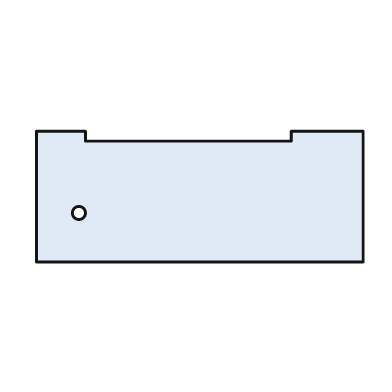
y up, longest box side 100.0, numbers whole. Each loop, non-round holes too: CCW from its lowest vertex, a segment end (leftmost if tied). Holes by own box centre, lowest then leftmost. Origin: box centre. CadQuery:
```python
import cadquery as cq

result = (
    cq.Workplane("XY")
    .moveTo(-50.0, -20.0)
    .lineTo(50.0, -20.0)
    .lineTo(50.0, 20.0)
    .lineTo(28.0, 20.0)
    .lineTo(28.0, 17.0)
    .lineTo(-35.0, 17.0)
    .lineTo(-35.0, 20.0)
    .lineTo(-50.0, 20.0)
    .close()
    .moveTo(-37.0, -5.0)
    .circle(2.0)
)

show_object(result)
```